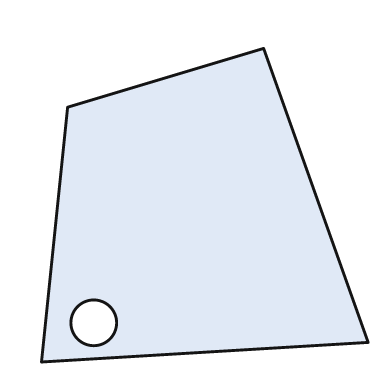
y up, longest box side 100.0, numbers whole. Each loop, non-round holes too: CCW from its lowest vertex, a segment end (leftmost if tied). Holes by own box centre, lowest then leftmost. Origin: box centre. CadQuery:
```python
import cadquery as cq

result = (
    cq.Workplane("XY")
    .moveTo(-50.0, -48.0)
    .lineTo(50.0, -42.0)
    .lineTo(18.0, 48.0)
    .lineTo(-42.0, 30.0)
    .close()
    .moveTo(-34.0, -36.0)
    .circle(7.0)
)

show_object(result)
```